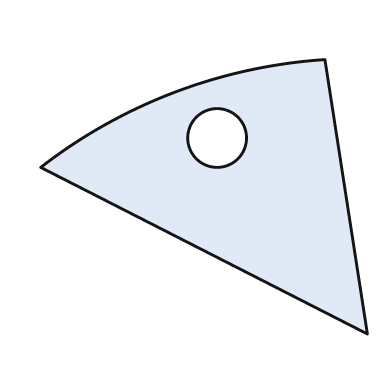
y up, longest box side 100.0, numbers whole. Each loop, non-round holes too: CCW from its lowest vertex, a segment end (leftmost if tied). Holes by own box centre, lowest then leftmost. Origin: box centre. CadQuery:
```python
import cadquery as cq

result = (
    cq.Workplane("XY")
    .moveTo(50.0, -42.0)
    .lineTo(37.0, 42.0)
    .threePointArc((-9.0, 32.0), (-50.0, 9.0))
    .close()
    .moveTo(4.0, 18.0)
    .circle(9.0)
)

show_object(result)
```